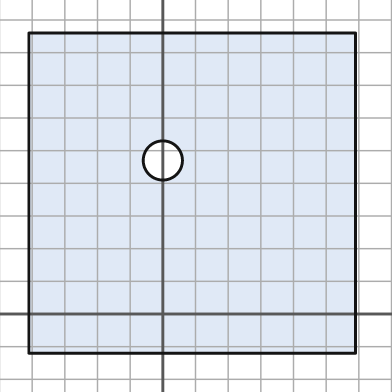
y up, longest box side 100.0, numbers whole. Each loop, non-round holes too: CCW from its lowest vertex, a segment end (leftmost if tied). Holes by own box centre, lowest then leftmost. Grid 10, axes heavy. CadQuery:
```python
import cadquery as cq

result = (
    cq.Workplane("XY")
    .moveTo(-41.0, -12.0)
    .lineTo(59.0, -12.0)
    .lineTo(59.0, 86.0)
    .lineTo(-41.0, 86.0)
    .close()
    .moveTo(0.0, 47.0)
    .circle(6.0)
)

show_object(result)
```